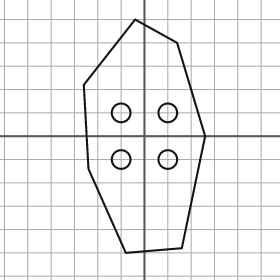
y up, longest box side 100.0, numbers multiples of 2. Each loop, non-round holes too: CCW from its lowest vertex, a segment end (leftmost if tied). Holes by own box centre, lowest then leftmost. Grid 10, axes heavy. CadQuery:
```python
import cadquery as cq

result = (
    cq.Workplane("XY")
    .moveTo(-8.0, -50.0)
    .lineTo(16.0, -48.0)
    .lineTo(26.0, 0.0)
    .lineTo(14.0, 40.0)
    .lineTo(-4.0, 50.0)
    .lineTo(-26.0, 22.0)
    .lineTo(-24.0, -14.0)
    .close()
    .moveTo(-10.0, -10.0)
    .circle(4.0)
    .moveTo(10.0, -10.0)
    .circle(4.0)
    .moveTo(-10.0, 10.0)
    .circle(4.0)
    .moveTo(10.0, 10.0)
    .circle(4.0)
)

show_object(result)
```